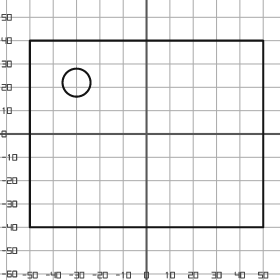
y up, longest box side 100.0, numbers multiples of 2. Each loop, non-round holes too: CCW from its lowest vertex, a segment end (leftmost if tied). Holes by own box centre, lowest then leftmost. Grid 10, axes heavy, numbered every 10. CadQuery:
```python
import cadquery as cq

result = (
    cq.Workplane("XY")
    .moveTo(-50.0, -40.0)
    .lineTo(50.0, -40.0)
    .lineTo(50.0, 40.0)
    .lineTo(-50.0, 40.0)
    .close()
    .moveTo(-30.0, 22.0)
    .circle(6.0)
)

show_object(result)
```